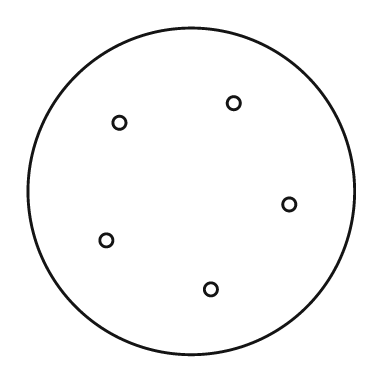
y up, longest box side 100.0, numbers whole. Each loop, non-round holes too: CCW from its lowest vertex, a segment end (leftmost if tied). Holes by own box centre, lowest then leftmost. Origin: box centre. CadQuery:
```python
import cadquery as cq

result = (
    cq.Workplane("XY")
    .moveTo(0.0, 0.0)
    .circle(50.0)
    .moveTo(6.0, -30.0)
    .circle(2.0)
    .moveTo(-26.0, -15.0)
    .circle(2.0)
    .moveTo(30.0, -4.0)
    .circle(2.0)
    .moveTo(-22.0, 21.0)
    .circle(2.0)
    .moveTo(13.0, 27.0)
    .circle(2.0)
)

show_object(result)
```